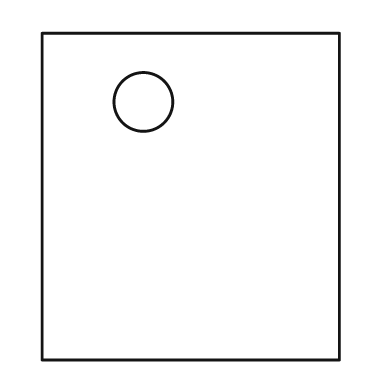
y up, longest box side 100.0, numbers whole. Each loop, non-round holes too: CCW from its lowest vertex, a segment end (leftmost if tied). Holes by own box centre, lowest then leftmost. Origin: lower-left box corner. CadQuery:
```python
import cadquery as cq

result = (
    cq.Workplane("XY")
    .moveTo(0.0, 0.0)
    .lineTo(91.0, 0.0)
    .lineTo(91.0, 100.0)
    .lineTo(0.0, 100.0)
    .close()
    .moveTo(31.0, 79.0)
    .circle(9.0)
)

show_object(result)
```